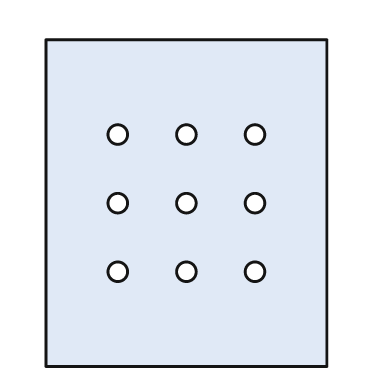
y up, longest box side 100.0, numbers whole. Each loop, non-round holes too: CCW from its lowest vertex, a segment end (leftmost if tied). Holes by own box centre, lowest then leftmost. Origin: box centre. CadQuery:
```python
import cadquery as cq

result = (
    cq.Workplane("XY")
    .moveTo(-43.0, -50.0)
    .lineTo(43.0, -50.0)
    .lineTo(43.0, 50.0)
    .lineTo(-43.0, 50.0)
    .close()
    .moveTo(-21.0, -21.0)
    .circle(3.0)
    .moveTo(0.0, -21.0)
    .circle(3.0)
    .moveTo(21.0, -21.0)
    .circle(3.0)
    .moveTo(-21.0, 0.0)
    .circle(3.0)
    .moveTo(0.0, 0.0)
    .circle(3.0)
    .moveTo(21.0, 0.0)
    .circle(3.0)
    .moveTo(-21.0, 21.0)
    .circle(3.0)
    .moveTo(0.0, 21.0)
    .circle(3.0)
    .moveTo(21.0, 21.0)
    .circle(3.0)
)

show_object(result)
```